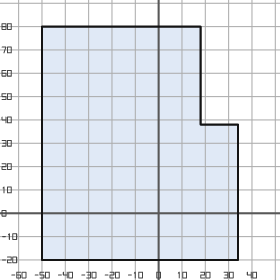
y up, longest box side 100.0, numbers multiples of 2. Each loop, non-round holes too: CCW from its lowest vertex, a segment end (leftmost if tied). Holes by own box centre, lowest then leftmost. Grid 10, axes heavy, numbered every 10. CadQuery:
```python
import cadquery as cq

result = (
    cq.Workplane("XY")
    .moveTo(-50.0, -20.0)
    .lineTo(34.0, -20.0)
    .lineTo(34.0, 38.0)
    .lineTo(18.0, 38.0)
    .lineTo(18.0, 80.0)
    .lineTo(-50.0, 80.0)
    .close()
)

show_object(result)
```